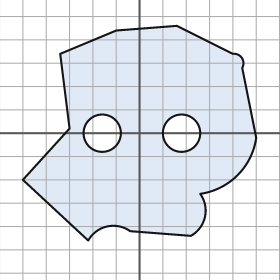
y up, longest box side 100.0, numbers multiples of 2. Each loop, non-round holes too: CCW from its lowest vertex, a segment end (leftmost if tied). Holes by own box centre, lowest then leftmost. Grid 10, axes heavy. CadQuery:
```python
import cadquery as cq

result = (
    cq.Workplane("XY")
    .moveTo(-22.0, -46.0)
    .threePointArc((-14.0, -40.0), (-4.0, -42.0))
    .lineTo(22.0, -44.0)
    .threePointArc((28.0, -36.0), (26.0, -26.0))
    .threePointArc((42.0, -18.0), (50.0, -2.0))
    .lineTo(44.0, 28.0)
    .threePointArc((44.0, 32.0), (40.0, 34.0))
    .lineTo(16.0, 46.0)
    .lineTo(-10.0, 44.0)
    .lineTo(-34.0, 34.0)
    .lineTo(-30.0, 2.0)
    .lineTo(-50.0, -20.0)
    .close()
    .moveTo(-16.0, 0.0)
    .circle(8.0)
    .moveTo(18.0, 0.0)
    .circle(8.0)
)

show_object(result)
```